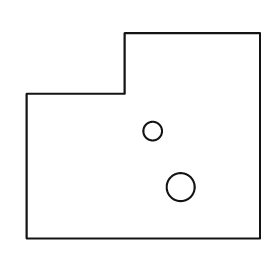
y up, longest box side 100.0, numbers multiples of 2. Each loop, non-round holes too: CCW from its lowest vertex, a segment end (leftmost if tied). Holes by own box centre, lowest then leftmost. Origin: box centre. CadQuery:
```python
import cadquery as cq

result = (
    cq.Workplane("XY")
    .moveTo(-50.0, -44.0)
    .lineTo(50.0, -44.0)
    .lineTo(50.0, 44.0)
    .lineTo(-8.0, 44.0)
    .lineTo(-8.0, 18.0)
    .lineTo(-50.0, 18.0)
    .close()
    .moveTo(16.0, -22.0)
    .circle(6.0)
    .moveTo(4.0, 2.0)
    .circle(4.0)
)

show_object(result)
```